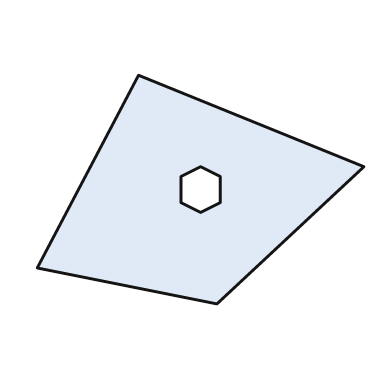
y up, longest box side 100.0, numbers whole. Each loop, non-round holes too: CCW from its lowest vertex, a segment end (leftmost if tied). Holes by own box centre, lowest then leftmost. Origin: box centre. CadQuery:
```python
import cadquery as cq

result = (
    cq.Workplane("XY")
    .moveTo(5.0, -35.0)
    .lineTo(50.0, 7.0)
    .lineTo(-19.0, 35.0)
    .lineTo(-50.0, -24.0)
    .close()
    .moveTo(0.0, -7.0)
    .lineTo(6.0, -4.0)
    .lineTo(6.0, 4.0)
    .lineTo(0.0, 7.0)
    .lineTo(-6.0, 4.0)
    .lineTo(-6.0, -4.0)
    .close()
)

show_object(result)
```